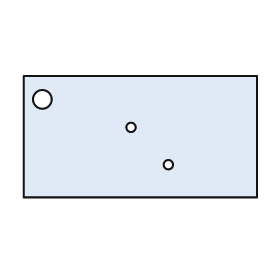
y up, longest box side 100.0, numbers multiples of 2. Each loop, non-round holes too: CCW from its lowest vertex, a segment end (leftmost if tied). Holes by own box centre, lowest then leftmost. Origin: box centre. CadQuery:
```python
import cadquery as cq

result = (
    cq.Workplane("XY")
    .moveTo(-50.0, -26.0)
    .lineTo(50.0, -26.0)
    .lineTo(50.0, 26.0)
    .lineTo(-50.0, 26.0)
    .close()
    .moveTo(12.0, -12.0)
    .circle(2.0)
    .moveTo(-4.0, 4.0)
    .circle(2.0)
    .moveTo(-42.0, 16.0)
    .circle(4.0)
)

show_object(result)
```